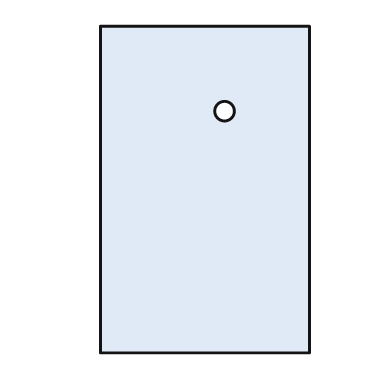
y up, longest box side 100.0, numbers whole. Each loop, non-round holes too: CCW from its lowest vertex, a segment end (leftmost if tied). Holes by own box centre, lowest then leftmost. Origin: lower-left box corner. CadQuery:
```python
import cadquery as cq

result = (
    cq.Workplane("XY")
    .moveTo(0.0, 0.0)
    .lineTo(64.0, 0.0)
    .lineTo(64.0, 100.0)
    .lineTo(0.0, 100.0)
    .close()
    .moveTo(38.0, 74.0)
    .circle(3.0)
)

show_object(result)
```